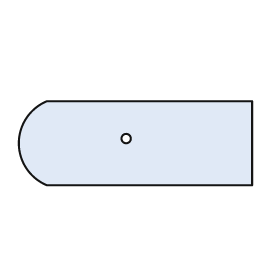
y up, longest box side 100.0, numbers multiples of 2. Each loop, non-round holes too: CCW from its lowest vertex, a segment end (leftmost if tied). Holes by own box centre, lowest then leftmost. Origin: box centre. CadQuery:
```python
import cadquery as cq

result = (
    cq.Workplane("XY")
    .moveTo(-38.0, -18.0)
    .lineTo(50.0, -18.0)
    .lineTo(50.0, 18.0)
    .lineTo(-38.0, 18.0)
    .threePointArc((-50.0, 0.0), (-38.0, -18.0))
    .close()
    .moveTo(-4.0, 2.0)
    .circle(2.0)
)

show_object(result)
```